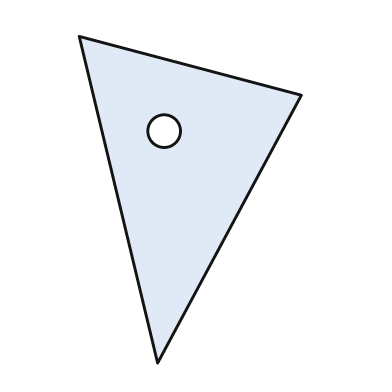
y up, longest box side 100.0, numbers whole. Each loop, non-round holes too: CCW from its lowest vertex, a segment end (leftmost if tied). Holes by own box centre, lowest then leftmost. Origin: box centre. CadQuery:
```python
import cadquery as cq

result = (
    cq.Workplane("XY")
    .moveTo(-10.0, -50.0)
    .lineTo(34.0, 32.0)
    .lineTo(-34.0, 50.0)
    .close()
    .moveTo(-8.0, 21.0)
    .circle(5.0)
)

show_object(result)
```